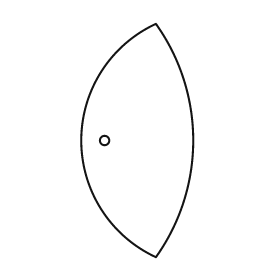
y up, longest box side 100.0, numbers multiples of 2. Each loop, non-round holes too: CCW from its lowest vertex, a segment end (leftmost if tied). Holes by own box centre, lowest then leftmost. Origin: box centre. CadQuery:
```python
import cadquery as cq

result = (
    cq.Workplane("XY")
    .moveTo(8.0, -50.0)
    .threePointArc((24.0, 0.0), (8.0, 50.0))
    .threePointArc((-24.0, 0.0), (8.0, -50.0))
    .close()
    .moveTo(-14.0, 0.0)
    .circle(2.0)
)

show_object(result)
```